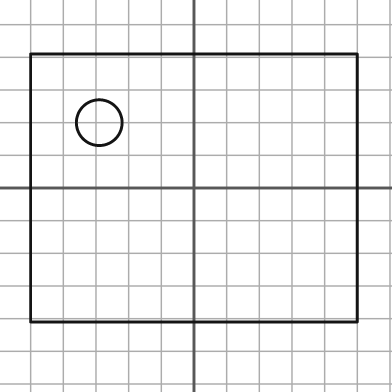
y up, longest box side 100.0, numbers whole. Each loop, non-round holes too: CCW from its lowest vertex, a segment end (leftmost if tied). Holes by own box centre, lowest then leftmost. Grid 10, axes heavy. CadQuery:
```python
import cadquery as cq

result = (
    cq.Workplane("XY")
    .moveTo(-50.0, -41.0)
    .lineTo(50.0, -41.0)
    .lineTo(50.0, 41.0)
    .lineTo(-50.0, 41.0)
    .close()
    .moveTo(-29.0, 20.0)
    .circle(7.0)
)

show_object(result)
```